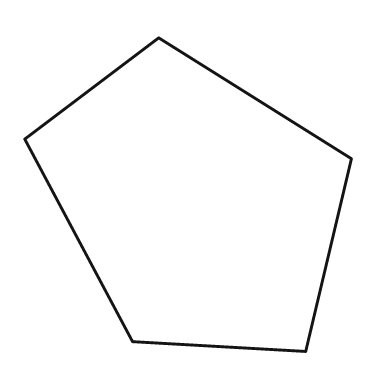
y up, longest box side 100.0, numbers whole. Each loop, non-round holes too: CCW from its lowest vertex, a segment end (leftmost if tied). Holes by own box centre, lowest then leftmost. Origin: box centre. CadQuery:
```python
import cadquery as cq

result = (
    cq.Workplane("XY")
    .moveTo(36.0, -48.0)
    .lineTo(50.0, 11.0)
    .lineTo(-9.0, 48.0)
    .lineTo(-50.0, 17.0)
    .lineTo(-17.0, -45.0)
    .close()
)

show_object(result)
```